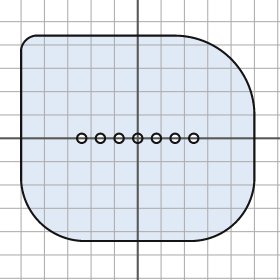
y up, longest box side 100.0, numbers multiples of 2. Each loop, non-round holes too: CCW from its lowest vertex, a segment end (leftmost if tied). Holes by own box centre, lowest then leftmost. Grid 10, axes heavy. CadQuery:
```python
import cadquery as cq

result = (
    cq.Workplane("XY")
    .moveTo(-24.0, -44.0)
    .lineTo(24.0, -44.0)
    .threePointArc((42.0, -36.0), (50.0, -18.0))
    .lineTo(50.0, 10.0)
    .threePointArc((40.0, 34.0), (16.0, 44.0))
    .lineTo(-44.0, 44.0)
    .threePointArc((-48.0, 42.0), (-50.0, 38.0))
    .lineTo(-50.0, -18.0)
    .threePointArc((-42.0, -36.0), (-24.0, -44.0))
    .close()
    .moveTo(-24.0, 0.0)
    .circle(2.0)
    .moveTo(-16.0, 0.0)
    .circle(2.0)
    .moveTo(-8.0, 0.0)
    .circle(2.0)
    .moveTo(0.0, 0.0)
    .circle(2.0)
    .moveTo(8.0, 0.0)
    .circle(2.0)
    .moveTo(16.0, 0.0)
    .circle(2.0)
    .moveTo(24.0, 0.0)
    .circle(2.0)
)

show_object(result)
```